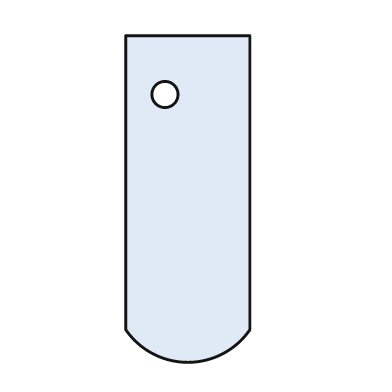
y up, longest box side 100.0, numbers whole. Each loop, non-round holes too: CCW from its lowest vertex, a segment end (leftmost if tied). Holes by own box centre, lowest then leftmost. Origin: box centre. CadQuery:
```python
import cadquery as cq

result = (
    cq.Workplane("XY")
    .moveTo(-19.0, -40.0)
    .threePointArc((0.0, -50.0), (19.0, -40.0))
    .lineTo(19.0, 50.0)
    .lineTo(-19.0, 50.0)
    .close()
    .moveTo(-7.0, 32.0)
    .circle(4.0)
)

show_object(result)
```